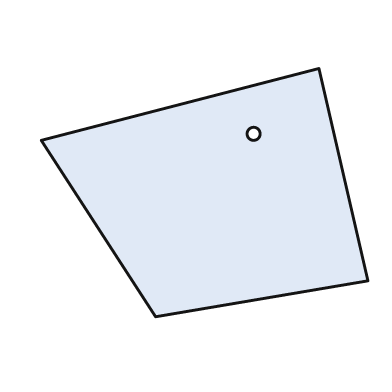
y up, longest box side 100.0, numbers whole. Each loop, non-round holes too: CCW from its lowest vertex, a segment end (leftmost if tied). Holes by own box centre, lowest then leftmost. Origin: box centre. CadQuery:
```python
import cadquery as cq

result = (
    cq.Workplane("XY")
    .moveTo(-15.0, -38.0)
    .lineTo(50.0, -27.0)
    .lineTo(35.0, 38.0)
    .lineTo(-50.0, 16.0)
    .close()
    .moveTo(15.0, 18.0)
    .circle(2.0)
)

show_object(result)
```